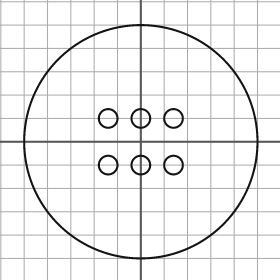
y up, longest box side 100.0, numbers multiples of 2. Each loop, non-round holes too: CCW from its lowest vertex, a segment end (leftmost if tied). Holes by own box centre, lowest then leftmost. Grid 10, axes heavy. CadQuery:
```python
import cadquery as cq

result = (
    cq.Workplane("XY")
    .moveTo(0.0, 0.0)
    .circle(50.0)
    .moveTo(-14.0, -10.0)
    .circle(4.0)
    .moveTo(0.0, -10.0)
    .circle(4.0)
    .moveTo(14.0, -10.0)
    .circle(4.0)
    .moveTo(-14.0, 10.0)
    .circle(4.0)
    .moveTo(0.0, 10.0)
    .circle(4.0)
    .moveTo(14.0, 10.0)
    .circle(4.0)
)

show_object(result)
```